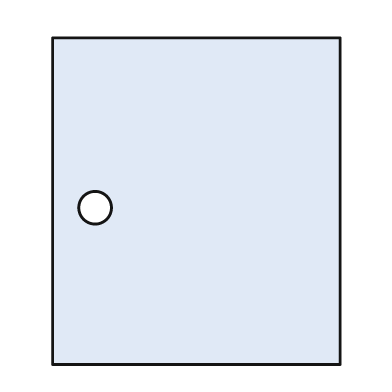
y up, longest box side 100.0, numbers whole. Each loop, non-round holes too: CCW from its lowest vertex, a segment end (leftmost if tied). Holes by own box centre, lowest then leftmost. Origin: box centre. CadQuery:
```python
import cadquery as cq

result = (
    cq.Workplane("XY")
    .moveTo(-44.0, -50.0)
    .lineTo(44.0, -50.0)
    .lineTo(44.0, 50.0)
    .lineTo(-44.0, 50.0)
    .close()
    .moveTo(-31.0, -2.0)
    .circle(5.0)
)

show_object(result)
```